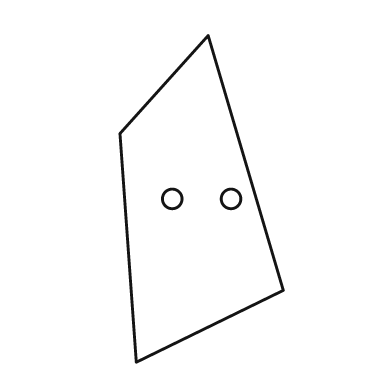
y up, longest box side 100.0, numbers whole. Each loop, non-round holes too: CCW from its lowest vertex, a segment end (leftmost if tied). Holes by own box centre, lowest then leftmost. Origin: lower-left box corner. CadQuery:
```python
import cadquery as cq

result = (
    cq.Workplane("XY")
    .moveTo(5.0, 0.0)
    .lineTo(50.0, 22.0)
    .lineTo(27.0, 100.0)
    .lineTo(0.0, 70.0)
    .close()
    .moveTo(16.0, 50.0)
    .circle(3.0)
    .moveTo(34.0, 50.0)
    .circle(3.0)
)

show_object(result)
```